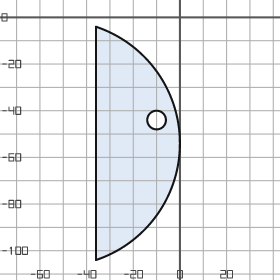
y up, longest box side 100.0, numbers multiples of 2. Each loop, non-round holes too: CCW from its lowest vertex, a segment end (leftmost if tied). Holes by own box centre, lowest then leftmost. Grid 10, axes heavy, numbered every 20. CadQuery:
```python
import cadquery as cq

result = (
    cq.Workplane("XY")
    .moveTo(-36.0, -104.0)
    .threePointArc((0.0, -54.0), (-36.0, -4.0))
    .close()
    .moveTo(-10.0, -44.0)
    .circle(4.0)
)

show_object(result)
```